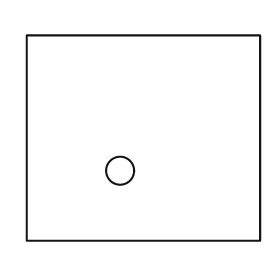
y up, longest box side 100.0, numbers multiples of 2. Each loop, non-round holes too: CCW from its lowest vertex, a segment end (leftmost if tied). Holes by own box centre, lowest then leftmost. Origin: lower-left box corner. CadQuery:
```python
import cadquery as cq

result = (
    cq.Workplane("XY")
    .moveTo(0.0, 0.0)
    .lineTo(100.0, 0.0)
    .lineTo(100.0, 88.0)
    .lineTo(0.0, 88.0)
    .close()
    .moveTo(40.0, 30.0)
    .circle(6.0)
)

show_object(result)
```